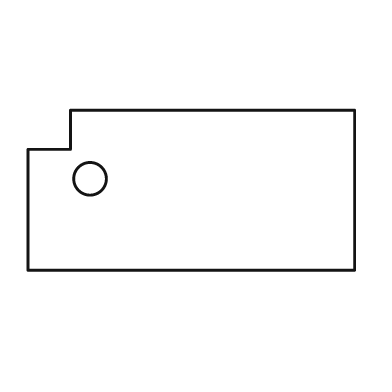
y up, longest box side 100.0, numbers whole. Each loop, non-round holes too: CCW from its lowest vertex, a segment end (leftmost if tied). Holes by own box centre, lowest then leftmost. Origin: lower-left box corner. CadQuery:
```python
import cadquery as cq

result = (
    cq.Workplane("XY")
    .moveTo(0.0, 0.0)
    .lineTo(100.0, 0.0)
    .lineTo(100.0, 49.0)
    .lineTo(13.0, 49.0)
    .lineTo(13.0, 37.0)
    .lineTo(0.0, 37.0)
    .close()
    .moveTo(19.0, 28.0)
    .circle(5.0)
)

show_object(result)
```